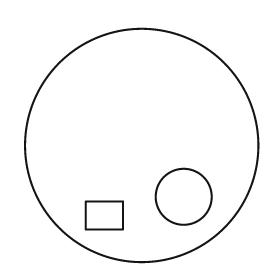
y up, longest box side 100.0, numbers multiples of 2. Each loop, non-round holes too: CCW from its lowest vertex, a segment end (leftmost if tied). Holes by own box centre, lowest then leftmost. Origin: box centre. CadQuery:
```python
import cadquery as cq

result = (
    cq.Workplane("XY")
    .moveTo(0.0, 0.0)
    .circle(50.0)
    .moveTo(-24.0, -36.0)
    .lineTo(-8.0, -36.0)
    .lineTo(-8.0, -24.0)
    .lineTo(-24.0, -24.0)
    .close()
    .moveTo(18.0, -22.0)
    .circle(12.0)
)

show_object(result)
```